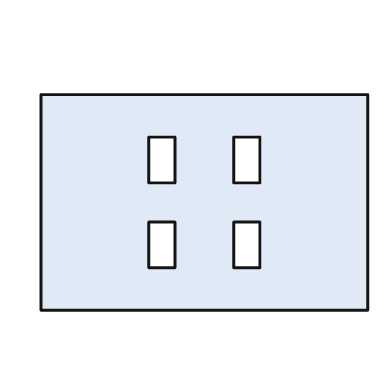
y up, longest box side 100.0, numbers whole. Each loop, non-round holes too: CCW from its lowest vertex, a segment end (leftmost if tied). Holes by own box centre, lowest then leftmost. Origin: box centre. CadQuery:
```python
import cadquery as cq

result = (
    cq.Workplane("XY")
    .moveTo(-50.0, -33.0)
    .lineTo(50.0, -33.0)
    .lineTo(50.0, 33.0)
    .lineTo(-50.0, 33.0)
    .close()
    .moveTo(-17.0, -20.0)
    .lineTo(-9.0, -20.0)
    .lineTo(-9.0, -6.0)
    .lineTo(-17.0, -6.0)
    .close()
    .moveTo(9.0, -20.0)
    .lineTo(17.0, -20.0)
    .lineTo(17.0, -6.0)
    .lineTo(9.0, -6.0)
    .close()
    .moveTo(-17.0, 6.0)
    .lineTo(-9.0, 6.0)
    .lineTo(-9.0, 20.0)
    .lineTo(-17.0, 20.0)
    .close()
    .moveTo(9.0, 6.0)
    .lineTo(17.0, 6.0)
    .lineTo(17.0, 20.0)
    .lineTo(9.0, 20.0)
    .close()
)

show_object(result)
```